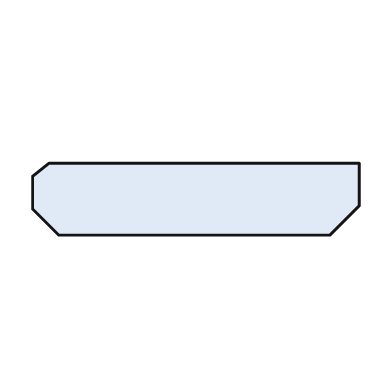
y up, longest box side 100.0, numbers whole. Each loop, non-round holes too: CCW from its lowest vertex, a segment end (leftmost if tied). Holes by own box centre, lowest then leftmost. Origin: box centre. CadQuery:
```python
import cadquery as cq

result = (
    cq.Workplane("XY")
    .moveTo(-42.0, -11.0)
    .lineTo(41.0, -11.0)
    .lineTo(50.0, -2.0)
    .lineTo(50.0, 11.0)
    .lineTo(-45.0, 11.0)
    .lineTo(-50.0, 7.0)
    .lineTo(-50.0, -3.0)
    .close()
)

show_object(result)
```